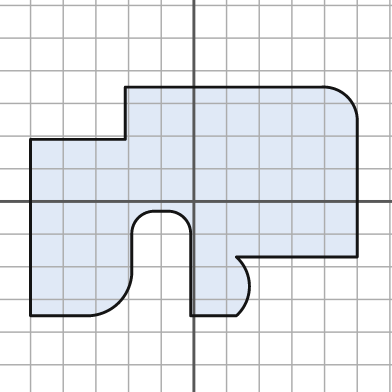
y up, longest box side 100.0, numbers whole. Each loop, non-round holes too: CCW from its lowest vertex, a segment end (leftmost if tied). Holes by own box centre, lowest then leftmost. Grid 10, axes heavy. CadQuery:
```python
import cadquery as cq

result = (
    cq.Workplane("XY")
    .moveTo(-50.0, -35.0)
    .lineTo(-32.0, -35.0)
    .threePointArc((-23.0, -31.0), (-19.0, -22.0))
    .lineTo(-19.0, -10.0)
    .threePointArc((-17.0, -5.0), (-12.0, -3.0))
    .lineTo(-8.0, -3.0)
    .threePointArc((-3.0, -5.0), (-1.0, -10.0))
    .lineTo(-1.0, -35.0)
    .lineTo(13.0, -35.0)
    .threePointArc((17.0, -26.0), (13.0, -17.0))
    .lineTo(50.0, -17.0)
    .lineTo(50.0, 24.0)
    .threePointArc((47.0, 32.0), (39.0, 35.0))
    .lineTo(-21.0, 35.0)
    .lineTo(-21.0, 19.0)
    .lineTo(-50.0, 19.0)
    .close()
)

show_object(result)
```